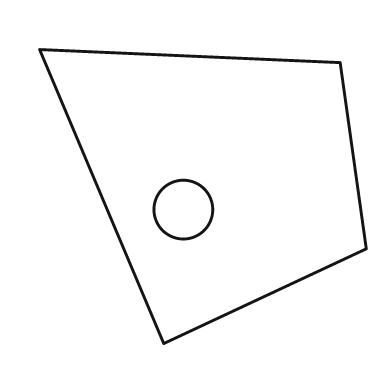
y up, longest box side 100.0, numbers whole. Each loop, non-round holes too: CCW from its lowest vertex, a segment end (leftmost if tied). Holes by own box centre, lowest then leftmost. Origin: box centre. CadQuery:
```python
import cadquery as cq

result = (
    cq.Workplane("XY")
    .moveTo(-12.0, -45.0)
    .lineTo(50.0, -16.0)
    .lineTo(42.0, 41.0)
    .lineTo(-50.0, 45.0)
    .close()
    .moveTo(-6.0, -4.0)
    .circle(9.0)
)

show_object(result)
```